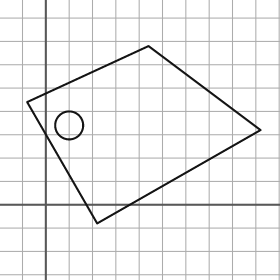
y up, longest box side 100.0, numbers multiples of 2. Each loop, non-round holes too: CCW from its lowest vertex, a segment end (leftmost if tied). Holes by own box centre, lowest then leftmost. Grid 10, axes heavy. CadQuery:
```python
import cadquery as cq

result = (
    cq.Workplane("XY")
    .moveTo(22.0, -8.0)
    .lineTo(92.0, 32.0)
    .lineTo(44.0, 68.0)
    .lineTo(-8.0, 44.0)
    .close()
    .moveTo(10.0, 34.0)
    .circle(6.0)
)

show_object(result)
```